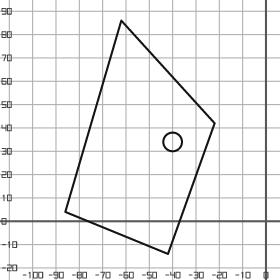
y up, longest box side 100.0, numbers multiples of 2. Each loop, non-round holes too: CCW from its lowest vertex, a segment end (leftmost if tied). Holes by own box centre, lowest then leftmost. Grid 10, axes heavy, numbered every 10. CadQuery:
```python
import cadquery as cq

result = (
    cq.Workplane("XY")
    .moveTo(-42.0, -14.0)
    .lineTo(-22.0, 42.0)
    .lineTo(-62.0, 86.0)
    .lineTo(-86.0, 4.0)
    .close()
    .moveTo(-40.0, 34.0)
    .circle(4.0)
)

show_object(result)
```